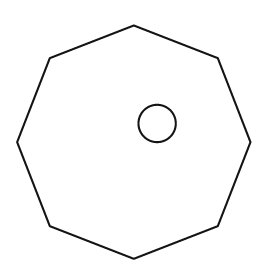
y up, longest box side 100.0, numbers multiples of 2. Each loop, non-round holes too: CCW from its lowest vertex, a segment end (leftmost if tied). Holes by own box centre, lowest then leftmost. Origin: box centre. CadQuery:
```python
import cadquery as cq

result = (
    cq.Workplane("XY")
    .moveTo(0.0, -50.0)
    .lineTo(36.0, -36.0)
    .lineTo(50.0, 0.0)
    .lineTo(36.0, 36.0)
    .lineTo(0.0, 50.0)
    .lineTo(-36.0, 36.0)
    .lineTo(-50.0, 0.0)
    .lineTo(-36.0, -36.0)
    .close()
    .moveTo(10.0, 8.0)
    .circle(8.0)
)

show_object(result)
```